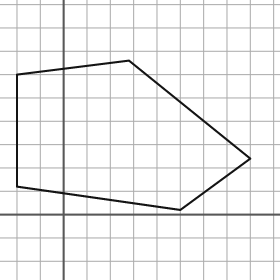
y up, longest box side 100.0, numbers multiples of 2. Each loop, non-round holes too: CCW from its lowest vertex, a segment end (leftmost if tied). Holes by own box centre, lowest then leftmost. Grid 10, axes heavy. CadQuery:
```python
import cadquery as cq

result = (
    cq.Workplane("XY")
    .moveTo(50.0, 2.0)
    .lineTo(80.0, 24.0)
    .lineTo(28.0, 66.0)
    .lineTo(-20.0, 60.0)
    .lineTo(-20.0, 12.0)
    .close()
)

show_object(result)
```